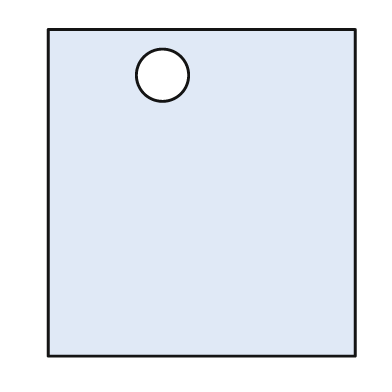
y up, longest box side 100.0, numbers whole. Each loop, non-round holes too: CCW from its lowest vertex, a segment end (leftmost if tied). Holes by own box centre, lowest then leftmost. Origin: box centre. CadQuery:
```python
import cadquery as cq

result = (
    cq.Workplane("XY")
    .moveTo(-47.0, -50.0)
    .lineTo(47.0, -50.0)
    .lineTo(47.0, 50.0)
    .lineTo(-47.0, 50.0)
    .close()
    .moveTo(-12.0, 36.0)
    .circle(8.0)
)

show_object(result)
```